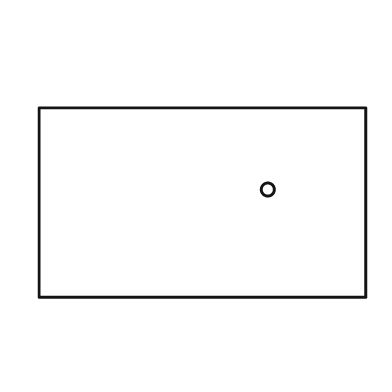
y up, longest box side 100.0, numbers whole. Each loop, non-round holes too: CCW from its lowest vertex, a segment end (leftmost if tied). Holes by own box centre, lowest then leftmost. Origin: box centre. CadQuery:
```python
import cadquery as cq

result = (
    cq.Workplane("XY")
    .moveTo(-50.0, -29.0)
    .lineTo(50.0, -29.0)
    .lineTo(50.0, 29.0)
    .lineTo(-50.0, 29.0)
    .close()
    .moveTo(20.0, 4.0)
    .circle(2.0)
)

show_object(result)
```